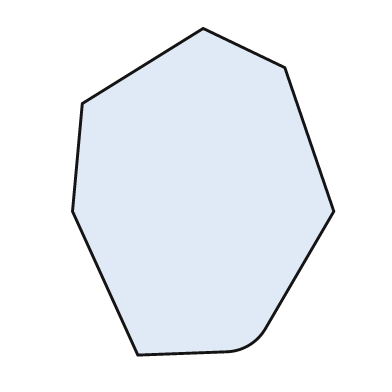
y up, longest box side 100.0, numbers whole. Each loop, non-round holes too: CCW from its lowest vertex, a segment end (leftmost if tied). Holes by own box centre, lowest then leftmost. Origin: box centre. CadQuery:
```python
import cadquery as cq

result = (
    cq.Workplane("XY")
    .moveTo(-20.0, -50.0)
    .lineTo(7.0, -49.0)
    .threePointArc((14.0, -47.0), (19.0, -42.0))
    .lineTo(40.0, -6.0)
    .lineTo(25.0, 38.0)
    .lineTo(0.0, 50.0)
    .lineTo(-37.0, 27.0)
    .lineTo(-40.0, -6.0)
    .close()
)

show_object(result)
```